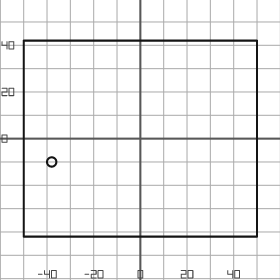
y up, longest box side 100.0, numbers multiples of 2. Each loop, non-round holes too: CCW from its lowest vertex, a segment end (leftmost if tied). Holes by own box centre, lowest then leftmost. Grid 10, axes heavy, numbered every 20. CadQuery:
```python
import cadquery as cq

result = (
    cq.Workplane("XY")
    .moveTo(-50.0, -42.0)
    .lineTo(50.0, -42.0)
    .lineTo(50.0, 42.0)
    .lineTo(-50.0, 42.0)
    .close()
    .moveTo(-38.0, -10.0)
    .circle(2.0)
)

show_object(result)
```